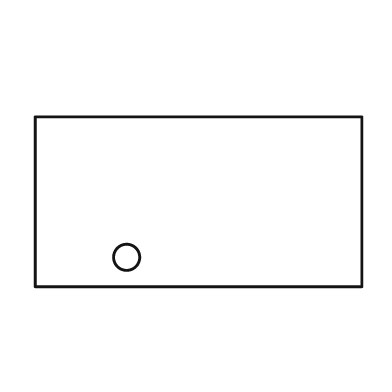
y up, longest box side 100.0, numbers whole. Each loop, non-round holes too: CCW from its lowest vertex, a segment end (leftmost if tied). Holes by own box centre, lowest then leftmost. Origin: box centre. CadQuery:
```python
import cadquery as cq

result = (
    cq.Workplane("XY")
    .moveTo(-50.0, -26.0)
    .lineTo(50.0, -26.0)
    .lineTo(50.0, 26.0)
    .lineTo(-50.0, 26.0)
    .close()
    .moveTo(-22.0, -17.0)
    .circle(4.0)
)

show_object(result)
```